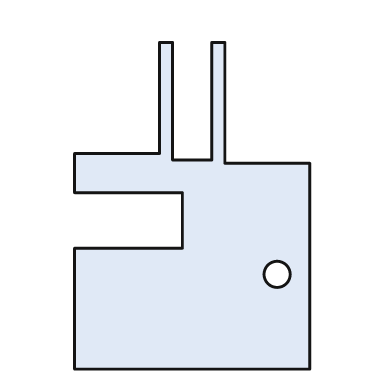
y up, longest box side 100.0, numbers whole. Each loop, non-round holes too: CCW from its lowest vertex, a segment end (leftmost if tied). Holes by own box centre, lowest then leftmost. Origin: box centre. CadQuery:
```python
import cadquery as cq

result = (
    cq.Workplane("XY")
    .moveTo(-36.0, -50.0)
    .lineTo(36.0, -50.0)
    .lineTo(36.0, 13.0)
    .lineTo(10.0, 13.0)
    .lineTo(10.0, 50.0)
    .lineTo(6.0, 50.0)
    .lineTo(6.0, 14.0)
    .lineTo(-6.0, 14.0)
    .lineTo(-6.0, 50.0)
    .lineTo(-10.0, 50.0)
    .lineTo(-10.0, 16.0)
    .lineTo(-36.0, 16.0)
    .lineTo(-36.0, 4.0)
    .lineTo(-3.0, 4.0)
    .lineTo(-3.0, -13.0)
    .lineTo(-36.0, -13.0)
    .close()
    .moveTo(26.0, -21.0)
    .circle(4.0)
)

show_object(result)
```